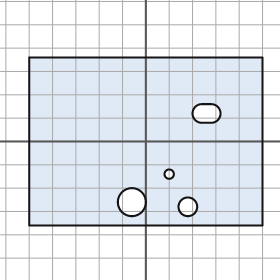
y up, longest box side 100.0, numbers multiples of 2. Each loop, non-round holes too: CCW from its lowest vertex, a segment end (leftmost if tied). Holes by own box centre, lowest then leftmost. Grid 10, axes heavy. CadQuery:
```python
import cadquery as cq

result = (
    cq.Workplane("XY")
    .moveTo(-50.0, -36.0)
    .lineTo(50.0, -36.0)
    .lineTo(50.0, 36.0)
    .lineTo(-50.0, 36.0)
    .close()
    .moveTo(18.0, -28.0)
    .circle(4.0)
    .moveTo(-6.0, -26.0)
    .circle(6.0)
    .moveTo(10.0, -14.0)
    .circle(2.0)
    .moveTo(24.0, 8.0)
    .lineTo(28.0, 8.0)
    .threePointArc((32.0, 12.0), (28.0, 16.0))
    .lineTo(24.0, 16.0)
    .threePointArc((20.0, 12.0), (24.0, 8.0))
    .close()
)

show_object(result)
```